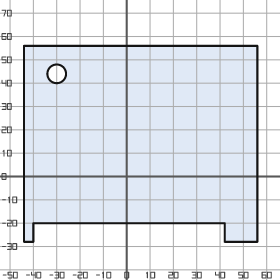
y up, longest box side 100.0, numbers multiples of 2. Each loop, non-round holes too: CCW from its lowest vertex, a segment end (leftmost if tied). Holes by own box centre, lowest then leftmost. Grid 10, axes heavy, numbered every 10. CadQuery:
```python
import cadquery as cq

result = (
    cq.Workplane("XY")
    .moveTo(-44.0, -28.0)
    .lineTo(-40.0, -28.0)
    .lineTo(-40.0, -20.0)
    .lineTo(42.0, -20.0)
    .lineTo(42.0, -28.0)
    .lineTo(56.0, -28.0)
    .lineTo(56.0, 56.0)
    .lineTo(-44.0, 56.0)
    .close()
    .moveTo(-30.0, 44.0)
    .circle(4.0)
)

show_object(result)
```